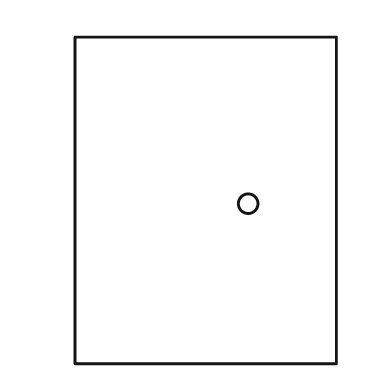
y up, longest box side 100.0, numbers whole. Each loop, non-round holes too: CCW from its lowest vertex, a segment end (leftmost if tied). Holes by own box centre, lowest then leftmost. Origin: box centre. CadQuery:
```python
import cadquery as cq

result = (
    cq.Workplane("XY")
    .moveTo(-40.0, -50.0)
    .lineTo(40.0, -50.0)
    .lineTo(40.0, 50.0)
    .lineTo(-40.0, 50.0)
    .close()
    .moveTo(13.0, -1.0)
    .circle(3.0)
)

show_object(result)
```